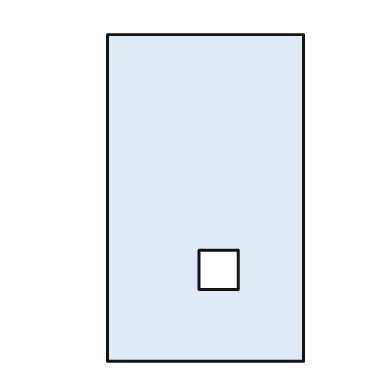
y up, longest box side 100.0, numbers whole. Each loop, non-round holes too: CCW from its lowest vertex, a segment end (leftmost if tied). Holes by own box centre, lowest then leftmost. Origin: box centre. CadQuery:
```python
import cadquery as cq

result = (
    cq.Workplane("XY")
    .moveTo(-30.0, -50.0)
    .lineTo(30.0, -50.0)
    .lineTo(30.0, 50.0)
    .lineTo(-30.0, 50.0)
    .close()
    .moveTo(-2.0, -28.0)
    .lineTo(10.0, -28.0)
    .lineTo(10.0, -16.0)
    .lineTo(-2.0, -16.0)
    .close()
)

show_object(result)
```